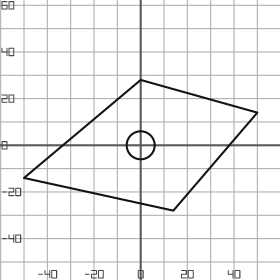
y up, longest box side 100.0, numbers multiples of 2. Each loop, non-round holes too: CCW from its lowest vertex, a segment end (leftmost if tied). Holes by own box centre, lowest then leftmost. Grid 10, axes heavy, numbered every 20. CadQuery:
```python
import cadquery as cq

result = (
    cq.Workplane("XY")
    .moveTo(14.0, -28.0)
    .lineTo(50.0, 14.0)
    .lineTo(0.0, 28.0)
    .lineTo(-50.0, -14.0)
    .close()
    .moveTo(0.0, 0.0)
    .circle(6.0)
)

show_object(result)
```